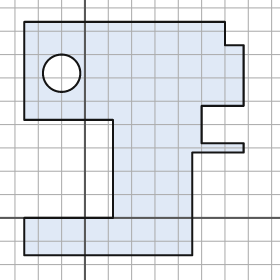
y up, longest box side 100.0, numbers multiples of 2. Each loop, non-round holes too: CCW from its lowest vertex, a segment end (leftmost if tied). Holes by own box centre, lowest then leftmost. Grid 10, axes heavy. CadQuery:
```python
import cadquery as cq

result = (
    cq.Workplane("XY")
    .moveTo(-26.0, -16.0)
    .lineTo(46.0, -16.0)
    .lineTo(46.0, 28.0)
    .lineTo(68.0, 28.0)
    .lineTo(68.0, 32.0)
    .lineTo(50.0, 32.0)
    .lineTo(50.0, 48.0)
    .lineTo(68.0, 48.0)
    .lineTo(68.0, 74.0)
    .lineTo(60.0, 74.0)
    .lineTo(60.0, 84.0)
    .lineTo(-26.0, 84.0)
    .lineTo(-26.0, 42.0)
    .lineTo(12.0, 42.0)
    .lineTo(12.0, 0.0)
    .lineTo(-26.0, 0.0)
    .close()
    .moveTo(-10.0, 62.0)
    .circle(8.0)
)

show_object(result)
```